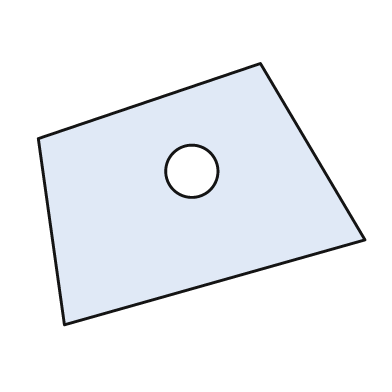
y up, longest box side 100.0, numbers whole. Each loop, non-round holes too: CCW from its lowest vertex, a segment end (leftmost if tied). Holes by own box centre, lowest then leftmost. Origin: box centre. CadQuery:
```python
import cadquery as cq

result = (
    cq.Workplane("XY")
    .moveTo(-42.0, -40.0)
    .lineTo(50.0, -14.0)
    .lineTo(18.0, 40.0)
    .lineTo(-50.0, 17.0)
    .close()
    .moveTo(-3.0, 7.0)
    .circle(8.0)
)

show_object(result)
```